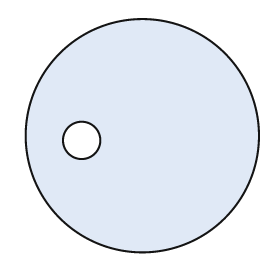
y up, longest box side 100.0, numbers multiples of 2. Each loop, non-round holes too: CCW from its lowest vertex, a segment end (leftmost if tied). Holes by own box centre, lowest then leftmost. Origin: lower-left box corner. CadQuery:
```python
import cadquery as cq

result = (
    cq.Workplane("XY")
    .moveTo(50.0, 50.0)
    .circle(50.0)
    .moveTo(24.0, 48.0)
    .circle(8.0)
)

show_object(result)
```